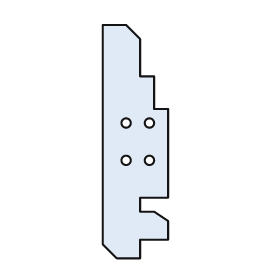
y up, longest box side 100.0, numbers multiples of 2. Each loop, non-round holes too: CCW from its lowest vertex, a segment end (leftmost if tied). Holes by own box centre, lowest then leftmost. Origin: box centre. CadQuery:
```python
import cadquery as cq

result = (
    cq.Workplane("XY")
    .moveTo(-8.0, -50.0)
    .lineTo(2.0, -50.0)
    .lineTo(2.0, -42.0)
    .lineTo(14.0, -42.0)
    .lineTo(14.0, -34.0)
    .lineTo(8.0, -30.0)
    .lineTo(2.0, -30.0)
    .lineTo(2.0, -24.0)
    .lineTo(14.0, -24.0)
    .lineTo(14.0, 14.0)
    .lineTo(8.0, 14.0)
    .lineTo(8.0, 28.0)
    .lineTo(2.0, 28.0)
    .lineTo(2.0, 44.0)
    .lineTo(-4.0, 50.0)
    .lineTo(-14.0, 50.0)
    .lineTo(-14.0, -44.0)
    .close()
    .moveTo(-4.0, -8.0)
    .circle(2.0)
    .moveTo(6.0, -8.0)
    .circle(2.0)
    .moveTo(-4.0, 8.0)
    .circle(2.0)
    .moveTo(6.0, 8.0)
    .circle(2.0)
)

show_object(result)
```